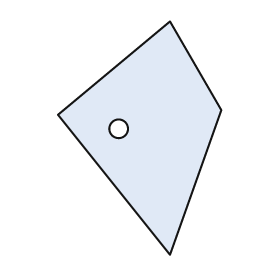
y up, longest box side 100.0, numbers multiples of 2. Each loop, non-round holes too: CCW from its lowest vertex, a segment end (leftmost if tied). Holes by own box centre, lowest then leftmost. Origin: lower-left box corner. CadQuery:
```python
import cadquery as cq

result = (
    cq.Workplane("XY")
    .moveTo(48.0, 0.0)
    .lineTo(70.0, 62.0)
    .lineTo(48.0, 100.0)
    .lineTo(0.0, 60.0)
    .close()
    .moveTo(26.0, 54.0)
    .circle(4.0)
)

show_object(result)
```